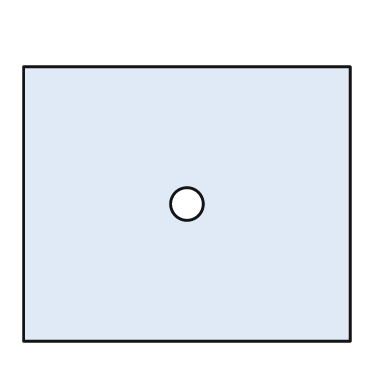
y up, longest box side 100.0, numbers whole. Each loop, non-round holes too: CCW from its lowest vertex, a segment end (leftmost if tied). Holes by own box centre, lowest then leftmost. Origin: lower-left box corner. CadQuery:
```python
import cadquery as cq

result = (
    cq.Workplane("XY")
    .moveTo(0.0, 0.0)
    .lineTo(100.0, 0.0)
    .lineTo(100.0, 84.0)
    .lineTo(0.0, 84.0)
    .close()
    .moveTo(50.0, 42.0)
    .circle(5.0)
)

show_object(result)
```